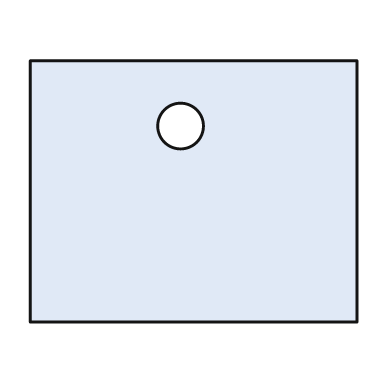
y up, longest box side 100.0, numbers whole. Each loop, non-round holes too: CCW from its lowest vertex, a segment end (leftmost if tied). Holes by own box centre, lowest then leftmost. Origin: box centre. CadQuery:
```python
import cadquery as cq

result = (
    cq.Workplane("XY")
    .moveTo(-50.0, -40.0)
    .lineTo(50.0, -40.0)
    .lineTo(50.0, 40.0)
    .lineTo(-50.0, 40.0)
    .close()
    .moveTo(-4.0, 20.0)
    .circle(7.0)
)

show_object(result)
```